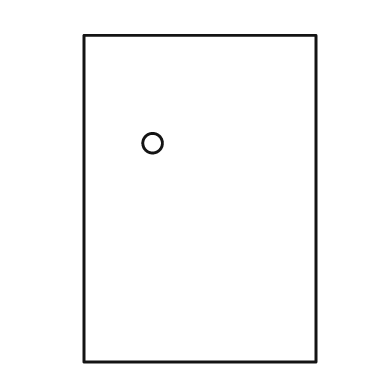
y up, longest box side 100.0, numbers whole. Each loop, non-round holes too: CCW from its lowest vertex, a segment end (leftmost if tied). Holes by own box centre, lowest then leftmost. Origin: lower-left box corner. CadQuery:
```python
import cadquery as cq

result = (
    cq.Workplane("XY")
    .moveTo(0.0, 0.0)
    .lineTo(71.0, 0.0)
    .lineTo(71.0, 100.0)
    .lineTo(0.0, 100.0)
    .close()
    .moveTo(21.0, 67.0)
    .circle(3.0)
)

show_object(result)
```